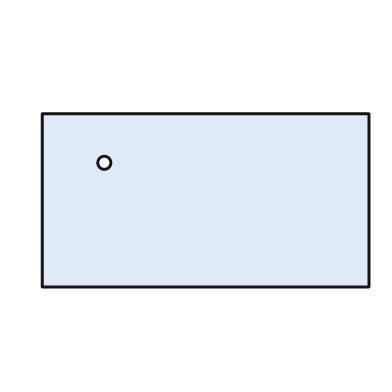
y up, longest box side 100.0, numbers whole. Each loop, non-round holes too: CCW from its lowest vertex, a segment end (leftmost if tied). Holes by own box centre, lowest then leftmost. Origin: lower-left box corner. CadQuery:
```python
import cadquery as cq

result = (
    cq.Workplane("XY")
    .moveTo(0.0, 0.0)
    .lineTo(100.0, 0.0)
    .lineTo(100.0, 53.0)
    .lineTo(0.0, 53.0)
    .close()
    .moveTo(19.0, 38.0)
    .circle(2.0)
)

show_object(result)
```